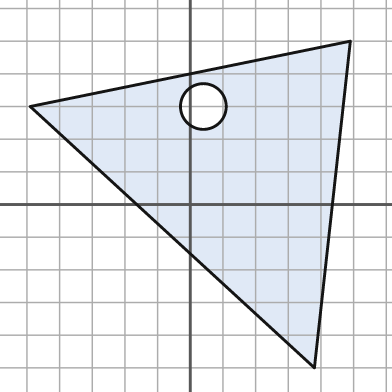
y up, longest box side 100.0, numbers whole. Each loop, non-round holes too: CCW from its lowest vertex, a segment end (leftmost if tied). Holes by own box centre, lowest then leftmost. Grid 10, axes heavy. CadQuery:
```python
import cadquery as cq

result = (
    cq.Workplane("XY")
    .moveTo(38.0, -50.0)
    .lineTo(49.0, 50.0)
    .lineTo(-49.0, 30.0)
    .close()
    .moveTo(4.0, 30.0)
    .circle(7.0)
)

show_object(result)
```